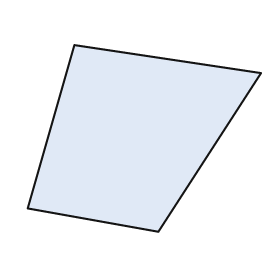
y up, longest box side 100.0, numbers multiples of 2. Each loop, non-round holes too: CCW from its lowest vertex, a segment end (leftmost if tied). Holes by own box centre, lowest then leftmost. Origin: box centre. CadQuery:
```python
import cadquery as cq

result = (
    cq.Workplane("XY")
    .moveTo(6.0, -40.0)
    .lineTo(50.0, 28.0)
    .lineTo(-30.0, 40.0)
    .lineTo(-50.0, -30.0)
    .close()
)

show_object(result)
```